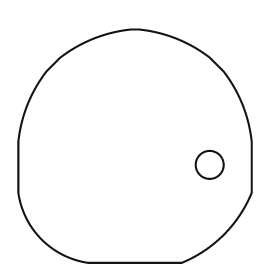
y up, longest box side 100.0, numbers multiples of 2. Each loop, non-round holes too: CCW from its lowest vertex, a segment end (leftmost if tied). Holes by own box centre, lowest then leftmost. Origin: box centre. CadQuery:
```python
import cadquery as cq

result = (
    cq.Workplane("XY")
    .moveTo(-20.0, -50.0)
    .lineTo(20.0, -50.0)
    .threePointArc((38.0, -38.0), (50.0, -20.0))
    .lineTo(50.0, 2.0)
    .threePointArc((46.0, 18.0), (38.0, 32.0))
    .lineTo(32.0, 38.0)
    .threePointArc((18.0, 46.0), (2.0, 50.0))
    .lineTo(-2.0, 50.0)
    .threePointArc((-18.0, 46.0), (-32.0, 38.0))
    .lineTo(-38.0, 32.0)
    .threePointArc((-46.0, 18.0), (-50.0, 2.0))
    .lineTo(-50.0, -20.0)
    .threePointArc((-40.0, -40.0), (-20.0, -50.0))
    .close()
    .moveTo(32.0, -8.0)
    .circle(6.0)
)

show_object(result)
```